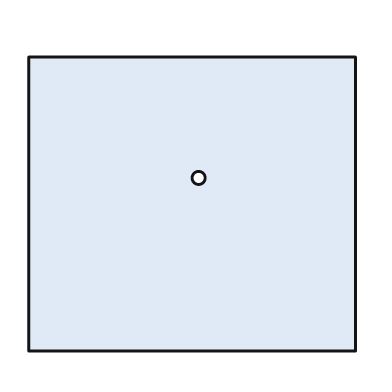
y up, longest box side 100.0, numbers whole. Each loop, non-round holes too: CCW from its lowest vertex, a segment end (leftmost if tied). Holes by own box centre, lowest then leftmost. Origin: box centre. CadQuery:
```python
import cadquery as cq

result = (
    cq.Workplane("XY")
    .moveTo(-50.0, -45.0)
    .lineTo(50.0, -45.0)
    .lineTo(50.0, 45.0)
    .lineTo(-50.0, 45.0)
    .close()
    .moveTo(2.0, 8.0)
    .circle(2.0)
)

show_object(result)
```